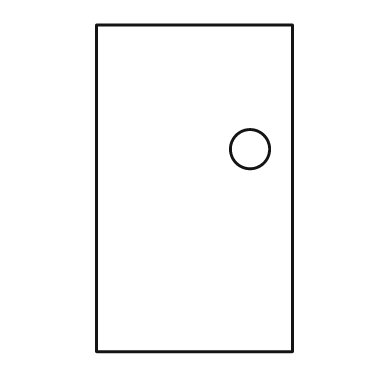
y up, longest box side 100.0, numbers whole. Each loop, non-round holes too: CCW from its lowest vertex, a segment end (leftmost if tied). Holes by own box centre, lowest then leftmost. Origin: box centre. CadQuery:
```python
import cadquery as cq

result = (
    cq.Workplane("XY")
    .moveTo(-30.0, -50.0)
    .lineTo(30.0, -50.0)
    .lineTo(30.0, 50.0)
    .lineTo(-30.0, 50.0)
    .close()
    .moveTo(17.0, 12.0)
    .circle(6.0)
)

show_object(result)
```